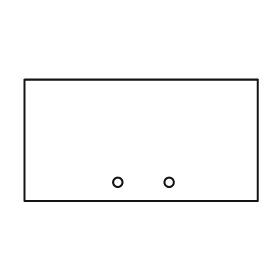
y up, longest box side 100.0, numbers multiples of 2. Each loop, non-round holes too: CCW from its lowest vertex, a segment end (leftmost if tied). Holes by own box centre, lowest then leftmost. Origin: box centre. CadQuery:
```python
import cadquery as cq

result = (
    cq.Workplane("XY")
    .moveTo(-50.0, -26.0)
    .lineTo(50.0, -26.0)
    .lineTo(50.0, 26.0)
    .lineTo(-50.0, 26.0)
    .close()
    .moveTo(-10.0, -18.0)
    .circle(2.0)
    .moveTo(12.0, -18.0)
    .circle(2.0)
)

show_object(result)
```